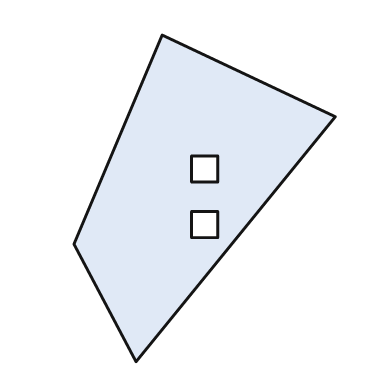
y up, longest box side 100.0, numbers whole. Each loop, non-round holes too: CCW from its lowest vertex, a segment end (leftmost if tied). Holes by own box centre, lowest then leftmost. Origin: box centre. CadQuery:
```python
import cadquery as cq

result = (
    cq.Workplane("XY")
    .moveTo(-21.0, -50.0)
    .lineTo(40.0, 25.0)
    .lineTo(-13.0, 50.0)
    .lineTo(-40.0, -14.0)
    .close()
    .moveTo(-4.0, -12.0)
    .lineTo(4.0, -12.0)
    .lineTo(4.0, -4.0)
    .lineTo(-4.0, -4.0)
    .close()
    .moveTo(-4.0, 5.0)
    .lineTo(4.0, 5.0)
    .lineTo(4.0, 13.0)
    .lineTo(-4.0, 13.0)
    .close()
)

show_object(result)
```